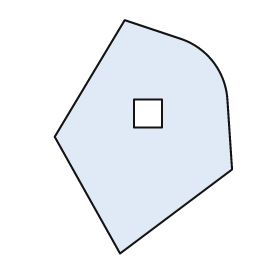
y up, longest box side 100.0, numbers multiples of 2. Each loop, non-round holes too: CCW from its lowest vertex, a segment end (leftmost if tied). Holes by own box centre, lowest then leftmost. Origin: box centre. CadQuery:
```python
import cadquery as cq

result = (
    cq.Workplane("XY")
    .moveTo(-10.0, -50.0)
    .lineTo(38.0, -14.0)
    .lineTo(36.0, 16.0)
    .threePointArc((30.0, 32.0), (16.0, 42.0))
    .lineTo(-8.0, 50.0)
    .lineTo(-38.0, 0.0)
    .close()
    .moveTo(-4.0, 4.0)
    .lineTo(8.0, 4.0)
    .lineTo(8.0, 16.0)
    .lineTo(-4.0, 16.0)
    .close()
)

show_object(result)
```